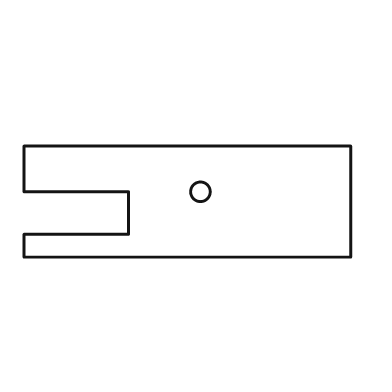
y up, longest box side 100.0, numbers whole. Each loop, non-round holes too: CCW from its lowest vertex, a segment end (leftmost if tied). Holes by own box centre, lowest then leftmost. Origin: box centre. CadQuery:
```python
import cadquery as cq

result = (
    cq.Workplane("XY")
    .moveTo(-50.0, -17.0)
    .lineTo(50.0, -17.0)
    .lineTo(50.0, 17.0)
    .lineTo(-50.0, 17.0)
    .lineTo(-50.0, 3.0)
    .lineTo(-18.0, 3.0)
    .lineTo(-18.0, -10.0)
    .lineTo(-50.0, -10.0)
    .close()
    .moveTo(4.0, 3.0)
    .circle(3.0)
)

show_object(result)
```